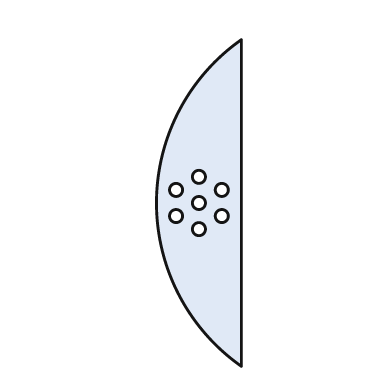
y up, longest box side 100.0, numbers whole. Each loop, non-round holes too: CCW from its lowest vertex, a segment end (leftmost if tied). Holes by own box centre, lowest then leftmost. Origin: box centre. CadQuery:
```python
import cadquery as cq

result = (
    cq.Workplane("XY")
    .moveTo(13.0, -50.0)
    .lineTo(13.0, 50.0)
    .threePointArc((-13.0, 0.0), (13.0, -50.0))
    .close()
    .moveTo(0.0, -8.0)
    .circle(2.0)
    .moveTo(-7.0, -4.0)
    .circle(2.0)
    .moveTo(7.0, -4.0)
    .circle(2.0)
    .moveTo(0.0, 0.0)
    .circle(2.0)
    .moveTo(-7.0, 4.0)
    .circle(2.0)
    .moveTo(7.0, 4.0)
    .circle(2.0)
    .moveTo(0.0, 8.0)
    .circle(2.0)
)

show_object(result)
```